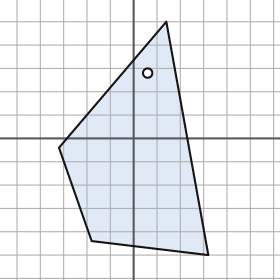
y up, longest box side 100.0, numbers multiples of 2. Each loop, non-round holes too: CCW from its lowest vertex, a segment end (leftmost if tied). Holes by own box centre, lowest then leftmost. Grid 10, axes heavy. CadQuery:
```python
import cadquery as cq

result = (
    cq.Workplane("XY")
    .moveTo(32.0, -50.0)
    .lineTo(14.0, 50.0)
    .lineTo(-32.0, -4.0)
    .lineTo(-18.0, -44.0)
    .close()
    .moveTo(6.0, 28.0)
    .circle(2.0)
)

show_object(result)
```